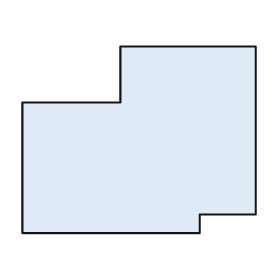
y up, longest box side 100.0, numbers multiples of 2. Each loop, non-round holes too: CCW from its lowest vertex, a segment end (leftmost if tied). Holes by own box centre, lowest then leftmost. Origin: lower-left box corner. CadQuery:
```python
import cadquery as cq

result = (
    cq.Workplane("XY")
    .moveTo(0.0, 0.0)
    .lineTo(76.0, 0.0)
    .lineTo(76.0, 8.0)
    .lineTo(100.0, 8.0)
    .lineTo(100.0, 80.0)
    .lineTo(42.0, 80.0)
    .lineTo(42.0, 56.0)
    .lineTo(0.0, 56.0)
    .close()
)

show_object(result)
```